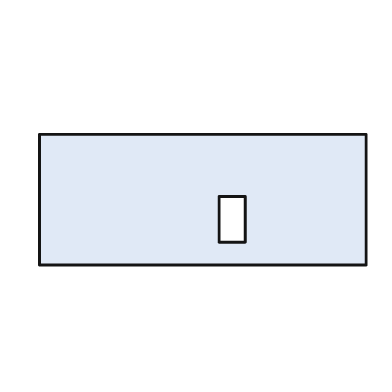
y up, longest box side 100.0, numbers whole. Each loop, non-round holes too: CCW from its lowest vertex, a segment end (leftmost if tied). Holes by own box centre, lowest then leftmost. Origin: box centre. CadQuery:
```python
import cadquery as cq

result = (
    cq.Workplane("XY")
    .moveTo(-50.0, -20.0)
    .lineTo(50.0, -20.0)
    .lineTo(50.0, 20.0)
    .lineTo(-50.0, 20.0)
    .close()
    .moveTo(5.0, -13.0)
    .lineTo(13.0, -13.0)
    .lineTo(13.0, 1.0)
    .lineTo(5.0, 1.0)
    .close()
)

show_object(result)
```